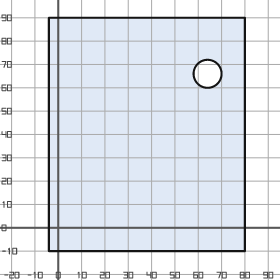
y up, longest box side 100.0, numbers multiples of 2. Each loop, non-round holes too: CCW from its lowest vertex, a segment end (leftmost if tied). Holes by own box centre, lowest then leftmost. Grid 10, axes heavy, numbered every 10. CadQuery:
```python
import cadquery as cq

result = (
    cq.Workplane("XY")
    .moveTo(-4.0, -10.0)
    .lineTo(80.0, -10.0)
    .lineTo(80.0, 90.0)
    .lineTo(-4.0, 90.0)
    .close()
    .moveTo(64.0, 66.0)
    .circle(6.0)
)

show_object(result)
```